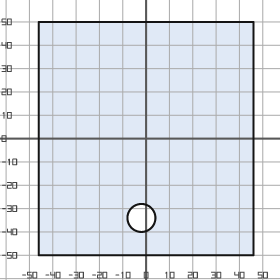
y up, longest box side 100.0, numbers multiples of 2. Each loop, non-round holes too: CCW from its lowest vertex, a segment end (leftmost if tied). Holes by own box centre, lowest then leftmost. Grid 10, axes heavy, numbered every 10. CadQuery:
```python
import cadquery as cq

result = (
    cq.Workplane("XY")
    .moveTo(-46.0, -50.0)
    .lineTo(46.0, -50.0)
    .lineTo(46.0, 50.0)
    .lineTo(-46.0, 50.0)
    .close()
    .moveTo(-2.0, -34.0)
    .circle(6.0)
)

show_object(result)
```